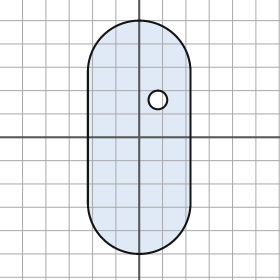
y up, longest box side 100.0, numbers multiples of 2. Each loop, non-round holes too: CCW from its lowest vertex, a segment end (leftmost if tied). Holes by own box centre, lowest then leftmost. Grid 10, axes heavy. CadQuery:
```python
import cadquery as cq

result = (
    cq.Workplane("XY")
    .moveTo(-22.0, -28.0)
    .threePointArc((0.0, -50.0), (22.0, -28.0))
    .lineTo(22.0, 28.0)
    .threePointArc((0.0, 50.0), (-22.0, 28.0))
    .close()
    .moveTo(8.0, 16.0)
    .circle(4.0)
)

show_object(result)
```